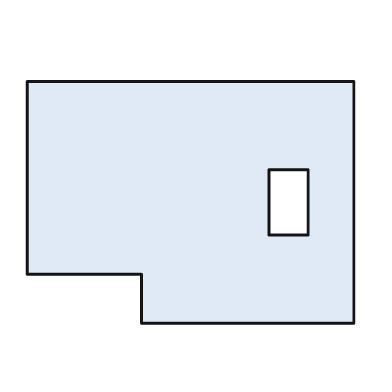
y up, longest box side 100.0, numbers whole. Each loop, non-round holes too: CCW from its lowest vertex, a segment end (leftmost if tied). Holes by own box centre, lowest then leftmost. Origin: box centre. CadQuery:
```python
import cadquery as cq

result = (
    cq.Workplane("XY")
    .moveTo(-15.0, -37.0)
    .lineTo(50.0, -37.0)
    .lineTo(50.0, 37.0)
    .lineTo(-50.0, 37.0)
    .lineTo(-50.0, -22.0)
    .lineTo(-15.0, -22.0)
    .close()
    .moveTo(24.0, -10.0)
    .lineTo(36.0, -10.0)
    .lineTo(36.0, 10.0)
    .lineTo(24.0, 10.0)
    .close()
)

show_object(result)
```